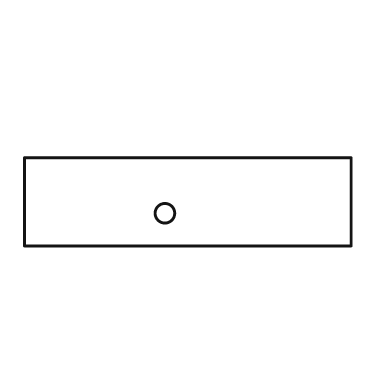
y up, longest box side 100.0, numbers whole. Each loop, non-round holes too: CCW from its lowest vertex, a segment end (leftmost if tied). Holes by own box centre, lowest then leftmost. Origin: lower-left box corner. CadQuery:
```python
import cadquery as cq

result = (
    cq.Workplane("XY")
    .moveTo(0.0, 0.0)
    .lineTo(100.0, 0.0)
    .lineTo(100.0, 27.0)
    .lineTo(0.0, 27.0)
    .close()
    .moveTo(43.0, 10.0)
    .circle(3.0)
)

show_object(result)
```